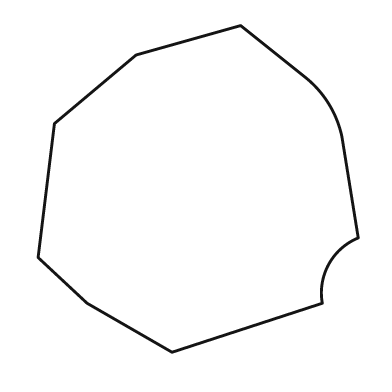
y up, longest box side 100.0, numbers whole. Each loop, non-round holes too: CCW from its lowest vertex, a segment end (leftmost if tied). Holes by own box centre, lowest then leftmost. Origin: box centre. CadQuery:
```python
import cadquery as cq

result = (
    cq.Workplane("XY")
    .moveTo(-8.0, -50.0)
    .lineTo(38.0, -35.0)
    .threePointArc((40.0, -23.0), (49.0, -15.0))
    .lineTo(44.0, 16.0)
    .threePointArc((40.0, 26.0), (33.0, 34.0))
    .lineTo(13.0, 50.0)
    .lineTo(-19.0, 41.0)
    .lineTo(-44.0, 20.0)
    .lineTo(-49.0, -21.0)
    .lineTo(-34.0, -35.0)
    .close()
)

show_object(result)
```